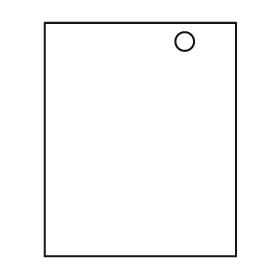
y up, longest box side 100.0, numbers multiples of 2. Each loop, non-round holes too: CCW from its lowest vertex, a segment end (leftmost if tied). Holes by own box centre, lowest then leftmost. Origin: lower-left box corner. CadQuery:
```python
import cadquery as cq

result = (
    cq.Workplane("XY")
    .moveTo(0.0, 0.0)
    .lineTo(82.0, 0.0)
    .lineTo(82.0, 100.0)
    .lineTo(0.0, 100.0)
    .close()
    .moveTo(60.0, 92.0)
    .circle(4.0)
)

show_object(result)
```